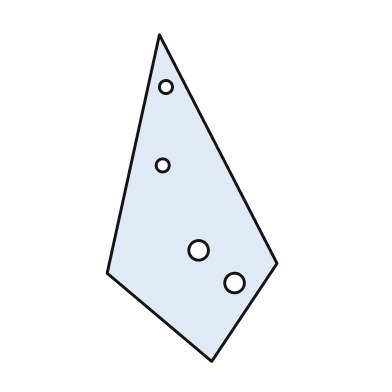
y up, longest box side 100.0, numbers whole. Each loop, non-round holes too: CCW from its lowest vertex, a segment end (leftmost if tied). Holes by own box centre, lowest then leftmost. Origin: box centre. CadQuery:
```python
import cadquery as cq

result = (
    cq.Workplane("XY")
    .moveTo(6.0, -50.0)
    .lineTo(26.0, -20.0)
    .lineTo(-10.0, 50.0)
    .lineTo(-26.0, -23.0)
    .close()
    .moveTo(13.0, -26.0)
    .circle(3.0)
    .moveTo(2.0, -16.0)
    .circle(3.0)
    .moveTo(-9.0, 10.0)
    .circle(2.0)
    .moveTo(-8.0, 34.0)
    .circle(2.0)
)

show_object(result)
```